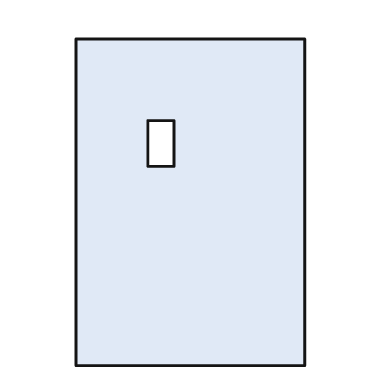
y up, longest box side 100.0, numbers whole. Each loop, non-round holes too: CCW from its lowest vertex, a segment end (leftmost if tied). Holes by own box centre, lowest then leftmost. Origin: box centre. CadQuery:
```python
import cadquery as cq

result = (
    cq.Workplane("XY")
    .moveTo(-35.0, -50.0)
    .lineTo(35.0, -50.0)
    .lineTo(35.0, 50.0)
    .lineTo(-35.0, 50.0)
    .close()
    .moveTo(-13.0, 11.0)
    .lineTo(-5.0, 11.0)
    .lineTo(-5.0, 25.0)
    .lineTo(-13.0, 25.0)
    .close()
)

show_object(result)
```